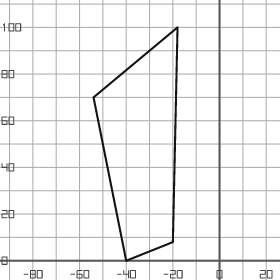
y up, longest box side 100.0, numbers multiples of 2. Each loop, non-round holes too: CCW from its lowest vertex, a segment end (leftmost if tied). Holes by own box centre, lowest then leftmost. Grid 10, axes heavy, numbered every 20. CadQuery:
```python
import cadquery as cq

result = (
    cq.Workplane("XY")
    .moveTo(-40.0, 0.0)
    .lineTo(-20.0, 8.0)
    .lineTo(-18.0, 100.0)
    .lineTo(-54.0, 70.0)
    .close()
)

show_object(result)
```